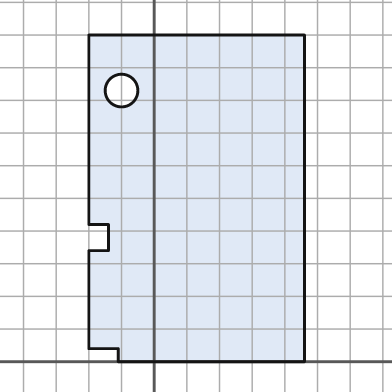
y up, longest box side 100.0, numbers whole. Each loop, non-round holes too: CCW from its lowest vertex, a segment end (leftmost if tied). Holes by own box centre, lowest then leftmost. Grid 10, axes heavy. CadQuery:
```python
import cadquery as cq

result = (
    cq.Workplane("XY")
    .moveTo(-11.0, 0.0)
    .lineTo(46.0, 0.0)
    .lineTo(46.0, 100.0)
    .lineTo(-20.0, 100.0)
    .lineTo(-20.0, 42.0)
    .lineTo(-14.0, 42.0)
    .lineTo(-14.0, 34.0)
    .lineTo(-20.0, 34.0)
    .lineTo(-20.0, 4.0)
    .lineTo(-11.0, 4.0)
    .close()
    .moveTo(-10.0, 83.0)
    .circle(5.0)
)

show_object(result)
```